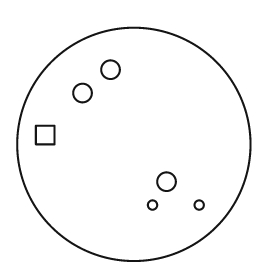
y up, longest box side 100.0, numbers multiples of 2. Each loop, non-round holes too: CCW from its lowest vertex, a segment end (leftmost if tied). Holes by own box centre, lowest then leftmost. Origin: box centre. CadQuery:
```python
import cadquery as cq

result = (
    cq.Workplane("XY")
    .moveTo(0.0, 0.0)
    .circle(50.0)
    .moveTo(8.0, -26.0)
    .circle(2.0)
    .moveTo(28.0, -26.0)
    .circle(2.0)
    .moveTo(14.0, -16.0)
    .circle(4.0)
    .moveTo(-42.0, 0.0)
    .lineTo(-34.0, 0.0)
    .lineTo(-34.0, 8.0)
    .lineTo(-42.0, 8.0)
    .close()
    .moveTo(-22.0, 22.0)
    .circle(4.0)
    .moveTo(-10.0, 32.0)
    .circle(4.0)
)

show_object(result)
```